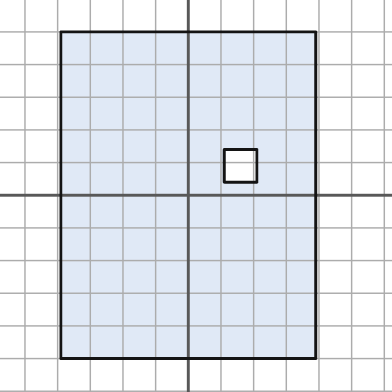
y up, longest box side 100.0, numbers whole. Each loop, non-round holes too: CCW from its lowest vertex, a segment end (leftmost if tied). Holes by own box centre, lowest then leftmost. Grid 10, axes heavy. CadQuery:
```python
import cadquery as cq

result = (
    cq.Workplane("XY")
    .moveTo(-39.0, -50.0)
    .lineTo(39.0, -50.0)
    .lineTo(39.0, 50.0)
    .lineTo(-39.0, 50.0)
    .close()
    .moveTo(11.0, 4.0)
    .lineTo(21.0, 4.0)
    .lineTo(21.0, 14.0)
    .lineTo(11.0, 14.0)
    .close()
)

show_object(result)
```